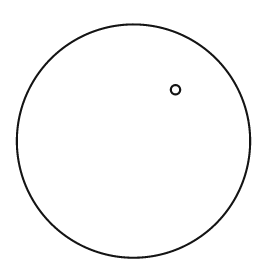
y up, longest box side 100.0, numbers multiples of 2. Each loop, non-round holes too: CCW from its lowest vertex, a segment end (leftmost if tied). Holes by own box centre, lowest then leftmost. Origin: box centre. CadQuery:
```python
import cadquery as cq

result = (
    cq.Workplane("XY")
    .moveTo(0.0, 0.0)
    .circle(50.0)
    .moveTo(18.0, 22.0)
    .circle(2.0)
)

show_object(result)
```